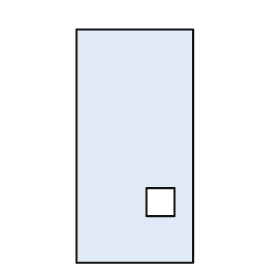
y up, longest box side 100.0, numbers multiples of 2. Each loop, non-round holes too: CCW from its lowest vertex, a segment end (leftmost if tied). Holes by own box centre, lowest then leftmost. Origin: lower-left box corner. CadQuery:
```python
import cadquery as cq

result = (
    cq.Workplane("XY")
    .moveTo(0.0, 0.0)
    .lineTo(50.0, 0.0)
    .lineTo(50.0, 100.0)
    .lineTo(0.0, 100.0)
    .close()
    .moveTo(30.0, 20.0)
    .lineTo(42.0, 20.0)
    .lineTo(42.0, 32.0)
    .lineTo(30.0, 32.0)
    .close()
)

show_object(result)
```